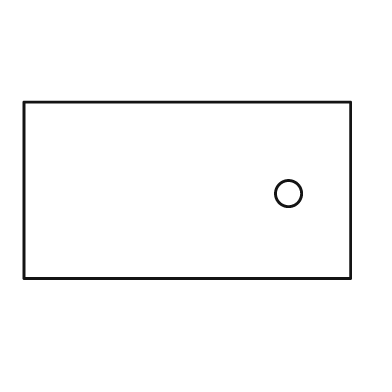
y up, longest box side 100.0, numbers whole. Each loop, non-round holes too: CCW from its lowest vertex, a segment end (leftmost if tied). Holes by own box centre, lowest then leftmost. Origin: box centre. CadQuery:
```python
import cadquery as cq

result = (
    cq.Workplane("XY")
    .moveTo(-50.0, -27.0)
    .lineTo(50.0, -27.0)
    .lineTo(50.0, 27.0)
    .lineTo(-50.0, 27.0)
    .close()
    .moveTo(31.0, -1.0)
    .circle(4.0)
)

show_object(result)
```